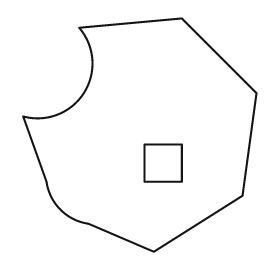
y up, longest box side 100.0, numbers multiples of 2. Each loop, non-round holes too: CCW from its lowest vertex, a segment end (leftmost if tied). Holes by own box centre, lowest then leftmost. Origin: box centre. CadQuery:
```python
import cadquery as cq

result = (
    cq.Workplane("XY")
    .moveTo(6.0, -50.0)
    .lineTo(44.0, -26.0)
    .lineTo(50.0, 18.0)
    .lineTo(18.0, 50.0)
    .lineTo(-26.0, 46.0)
    .threePointArc((-24.0, 18.0), (-50.0, 8.0))
    .lineTo(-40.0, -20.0)
    .threePointArc((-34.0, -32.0), (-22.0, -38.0))
    .close()
    .moveTo(2.0, -20.0)
    .lineTo(18.0, -20.0)
    .lineTo(18.0, -4.0)
    .lineTo(2.0, -4.0)
    .close()
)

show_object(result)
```